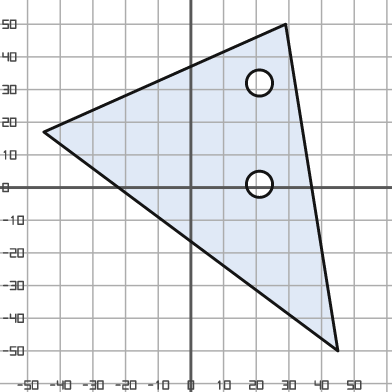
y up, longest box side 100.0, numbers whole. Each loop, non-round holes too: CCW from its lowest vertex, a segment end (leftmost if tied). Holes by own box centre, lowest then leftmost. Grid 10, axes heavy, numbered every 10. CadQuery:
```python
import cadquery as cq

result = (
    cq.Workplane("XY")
    .moveTo(45.0, -50.0)
    .lineTo(29.0, 50.0)
    .lineTo(-45.0, 17.0)
    .close()
    .moveTo(21.0, 1.0)
    .circle(4.0)
    .moveTo(21.0, 32.0)
    .circle(4.0)
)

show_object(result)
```